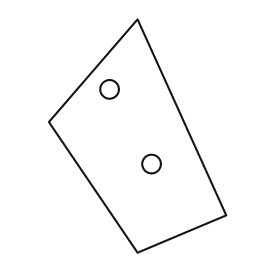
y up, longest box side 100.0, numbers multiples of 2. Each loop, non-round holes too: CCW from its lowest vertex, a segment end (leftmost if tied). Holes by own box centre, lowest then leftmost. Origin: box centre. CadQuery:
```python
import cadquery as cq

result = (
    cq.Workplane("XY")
    .moveTo(0.0, -50.0)
    .lineTo(38.0, -34.0)
    .lineTo(0.0, 50.0)
    .lineTo(-38.0, 6.0)
    .close()
    .moveTo(6.0, -12.0)
    .circle(4.0)
    .moveTo(-12.0, 20.0)
    .circle(4.0)
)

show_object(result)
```